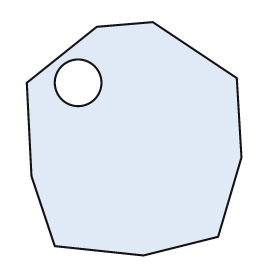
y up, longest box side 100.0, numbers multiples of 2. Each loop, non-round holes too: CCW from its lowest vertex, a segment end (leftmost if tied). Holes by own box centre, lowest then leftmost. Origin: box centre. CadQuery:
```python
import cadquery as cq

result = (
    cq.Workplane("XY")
    .moveTo(4.0, -50.0)
    .lineTo(36.0, -42.0)
    .lineTo(46.0, -8.0)
    .lineTo(44.0, 26.0)
    .lineTo(8.0, 50.0)
    .lineTo(-16.0, 48.0)
    .lineTo(-46.0, 24.0)
    .lineTo(-44.0, -16.0)
    .lineTo(-34.0, -46.0)
    .close()
    .moveTo(-24.0, 24.0)
    .circle(10.0)
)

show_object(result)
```